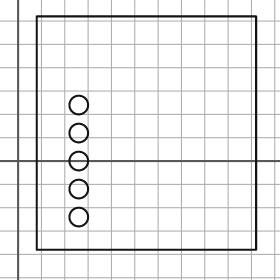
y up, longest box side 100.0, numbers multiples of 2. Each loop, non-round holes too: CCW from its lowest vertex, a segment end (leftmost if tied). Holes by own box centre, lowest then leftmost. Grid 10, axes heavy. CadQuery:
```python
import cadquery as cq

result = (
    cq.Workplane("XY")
    .moveTo(8.0, -38.0)
    .lineTo(102.0, -38.0)
    .lineTo(102.0, 62.0)
    .lineTo(8.0, 62.0)
    .close()
    .moveTo(26.0, -24.0)
    .circle(4.0)
    .moveTo(26.0, -12.0)
    .circle(4.0)
    .moveTo(26.0, 0.0)
    .circle(4.0)
    .moveTo(26.0, 12.0)
    .circle(4.0)
    .moveTo(26.0, 24.0)
    .circle(4.0)
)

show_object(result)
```